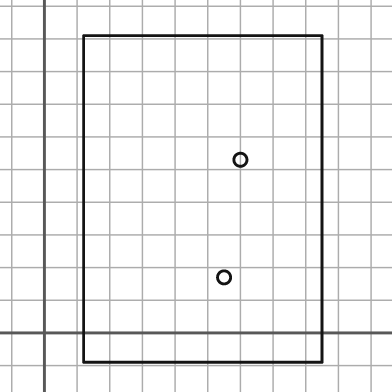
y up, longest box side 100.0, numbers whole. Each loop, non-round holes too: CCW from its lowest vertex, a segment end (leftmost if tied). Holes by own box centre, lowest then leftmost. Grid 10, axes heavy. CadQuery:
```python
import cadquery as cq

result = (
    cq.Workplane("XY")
    .moveTo(12.0, -9.0)
    .lineTo(85.0, -9.0)
    .lineTo(85.0, 91.0)
    .lineTo(12.0, 91.0)
    .close()
    .moveTo(55.0, 17.0)
    .circle(2.0)
    .moveTo(60.0, 53.0)
    .circle(2.0)
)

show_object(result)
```